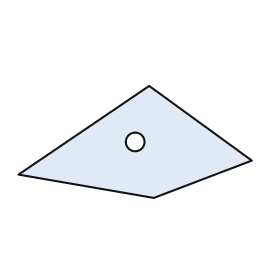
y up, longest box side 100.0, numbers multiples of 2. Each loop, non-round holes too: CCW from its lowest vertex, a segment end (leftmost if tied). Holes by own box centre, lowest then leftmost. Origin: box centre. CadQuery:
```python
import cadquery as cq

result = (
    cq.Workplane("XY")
    .moveTo(8.0, -24.0)
    .lineTo(50.0, -8.0)
    .lineTo(6.0, 24.0)
    .lineTo(-50.0, -14.0)
    .close()
    .moveTo(0.0, 0.0)
    .circle(4.0)
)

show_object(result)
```